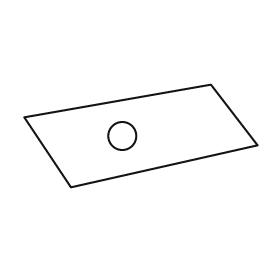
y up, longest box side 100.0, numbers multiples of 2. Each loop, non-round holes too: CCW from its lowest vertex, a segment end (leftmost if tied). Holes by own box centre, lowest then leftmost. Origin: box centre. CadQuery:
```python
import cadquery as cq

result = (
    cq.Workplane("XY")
    .moveTo(-30.0, -22.0)
    .lineTo(50.0, -4.0)
    .lineTo(30.0, 22.0)
    .lineTo(-50.0, 8.0)
    .close()
    .moveTo(-8.0, 0.0)
    .circle(6.0)
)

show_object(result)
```